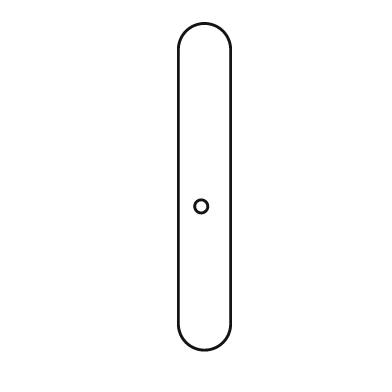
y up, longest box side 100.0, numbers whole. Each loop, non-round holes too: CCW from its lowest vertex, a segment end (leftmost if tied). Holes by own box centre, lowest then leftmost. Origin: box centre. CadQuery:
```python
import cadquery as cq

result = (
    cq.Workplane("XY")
    .moveTo(-8.0, -42.0)
    .threePointArc((0.0, -50.0), (8.0, -42.0))
    .lineTo(8.0, 42.0)
    .threePointArc((0.0, 50.0), (-8.0, 42.0))
    .close()
    .moveTo(-1.0, -6.0)
    .circle(2.0)
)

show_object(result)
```